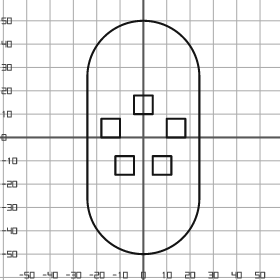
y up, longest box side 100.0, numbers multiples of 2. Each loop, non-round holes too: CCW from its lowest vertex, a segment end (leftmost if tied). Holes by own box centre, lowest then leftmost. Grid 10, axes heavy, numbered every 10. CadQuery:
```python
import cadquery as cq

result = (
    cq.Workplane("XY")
    .moveTo(-24.0, -26.0)
    .threePointArc((0.0, -50.0), (24.0, -26.0))
    .lineTo(24.0, 26.0)
    .threePointArc((0.0, 50.0), (-24.0, 26.0))
    .close()
    .moveTo(-12.0, -16.0)
    .lineTo(-4.0, -16.0)
    .lineTo(-4.0, -8.0)
    .lineTo(-12.0, -8.0)
    .close()
    .moveTo(4.0, -16.0)
    .lineTo(12.0, -16.0)
    .lineTo(12.0, -8.0)
    .lineTo(4.0, -8.0)
    .close()
    .moveTo(-18.0, 0.0)
    .lineTo(-10.0, 0.0)
    .lineTo(-10.0, 8.0)
    .lineTo(-18.0, 8.0)
    .close()
    .moveTo(10.0, 0.0)
    .lineTo(18.0, 0.0)
    .lineTo(18.0, 8.0)
    .lineTo(10.0, 8.0)
    .close()
    .moveTo(-4.0, 10.0)
    .lineTo(4.0, 10.0)
    .lineTo(4.0, 18.0)
    .lineTo(-4.0, 18.0)
    .close()
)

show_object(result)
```